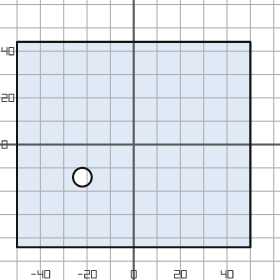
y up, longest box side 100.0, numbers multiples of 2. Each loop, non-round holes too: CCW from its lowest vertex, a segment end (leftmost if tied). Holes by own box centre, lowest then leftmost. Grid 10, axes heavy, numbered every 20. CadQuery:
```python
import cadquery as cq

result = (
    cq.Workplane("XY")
    .moveTo(-50.0, -44.0)
    .lineTo(50.0, -44.0)
    .lineTo(50.0, 44.0)
    .lineTo(-50.0, 44.0)
    .close()
    .moveTo(-22.0, -14.0)
    .circle(4.0)
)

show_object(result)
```